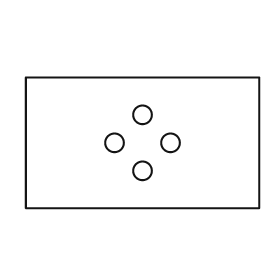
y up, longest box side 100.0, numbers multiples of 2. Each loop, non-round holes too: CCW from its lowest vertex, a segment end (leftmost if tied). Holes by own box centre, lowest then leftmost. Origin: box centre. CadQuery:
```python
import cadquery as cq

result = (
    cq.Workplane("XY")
    .moveTo(-50.0, -28.0)
    .lineTo(50.0, -28.0)
    .lineTo(50.0, 28.0)
    .lineTo(-50.0, 28.0)
    .close()
    .moveTo(0.0, -12.0)
    .circle(4.0)
    .moveTo(-12.0, 0.0)
    .circle(4.0)
    .moveTo(12.0, 0.0)
    .circle(4.0)
    .moveTo(0.0, 12.0)
    .circle(4.0)
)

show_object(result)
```